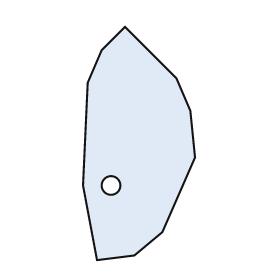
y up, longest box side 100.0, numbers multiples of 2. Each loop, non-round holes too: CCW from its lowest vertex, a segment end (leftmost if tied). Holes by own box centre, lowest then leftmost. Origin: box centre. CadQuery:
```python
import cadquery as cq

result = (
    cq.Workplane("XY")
    .moveTo(-18.0, -50.0)
    .lineTo(-2.0, -48.0)
    .lineTo(10.0, -38.0)
    .lineTo(24.0, -6.0)
    .lineTo(22.0, 14.0)
    .lineTo(16.0, 28.0)
    .lineTo(-6.0, 50.0)
    .lineTo(-16.0, 40.0)
    .lineTo(-22.0, 26.0)
    .lineTo(-24.0, -18.0)
    .close()
    .moveTo(-12.0, -18.0)
    .circle(4.0)
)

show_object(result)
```